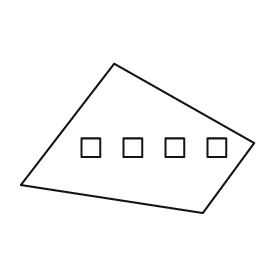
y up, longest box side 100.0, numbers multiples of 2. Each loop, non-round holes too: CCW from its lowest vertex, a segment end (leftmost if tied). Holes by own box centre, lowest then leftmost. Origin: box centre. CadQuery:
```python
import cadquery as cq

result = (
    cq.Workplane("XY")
    .moveTo(28.0, -32.0)
    .lineTo(50.0, -2.0)
    .lineTo(-10.0, 32.0)
    .lineTo(-50.0, -20.0)
    .close()
    .moveTo(-24.0, -8.0)
    .lineTo(-16.0, -8.0)
    .lineTo(-16.0, 0.0)
    .lineTo(-24.0, 0.0)
    .close()
    .moveTo(-6.0, -8.0)
    .lineTo(2.0, -8.0)
    .lineTo(2.0, 0.0)
    .lineTo(-6.0, 0.0)
    .close()
    .moveTo(12.0, -8.0)
    .lineTo(20.0, -8.0)
    .lineTo(20.0, 0.0)
    .lineTo(12.0, 0.0)
    .close()
    .moveTo(30.0, -8.0)
    .lineTo(38.0, -8.0)
    .lineTo(38.0, 0.0)
    .lineTo(30.0, 0.0)
    .close()
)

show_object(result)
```